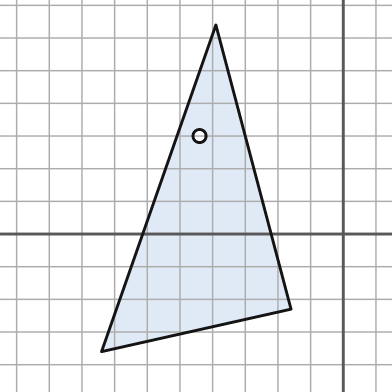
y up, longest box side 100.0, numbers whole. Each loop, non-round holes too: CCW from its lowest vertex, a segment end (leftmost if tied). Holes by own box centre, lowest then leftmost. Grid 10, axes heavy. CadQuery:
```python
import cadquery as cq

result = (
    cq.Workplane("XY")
    .moveTo(-74.0, -36.0)
    .lineTo(-16.0, -23.0)
    .lineTo(-39.0, 64.0)
    .close()
    .moveTo(-44.0, 30.0)
    .circle(2.0)
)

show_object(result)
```